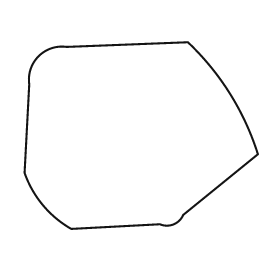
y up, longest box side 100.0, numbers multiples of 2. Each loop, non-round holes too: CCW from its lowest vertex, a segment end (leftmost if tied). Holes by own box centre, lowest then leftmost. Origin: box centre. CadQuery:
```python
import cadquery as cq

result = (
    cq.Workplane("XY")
    .moveTo(-30.0, -40.0)
    .lineTo(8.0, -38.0)
    .threePointArc((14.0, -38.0), (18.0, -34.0))
    .lineTo(50.0, -8.0)
    .threePointArc((38.0, 18.0), (20.0, 40.0))
    .lineTo(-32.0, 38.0)
    .threePointArc((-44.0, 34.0), (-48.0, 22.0))
    .lineTo(-50.0, -16.0)
    .threePointArc((-42.0, -30.0), (-30.0, -40.0))
    .close()
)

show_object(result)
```